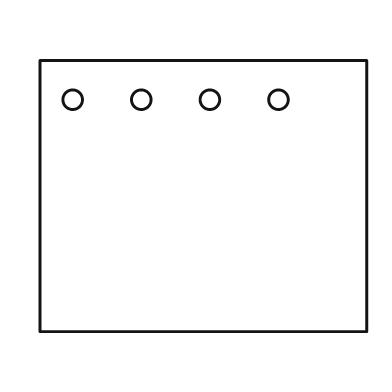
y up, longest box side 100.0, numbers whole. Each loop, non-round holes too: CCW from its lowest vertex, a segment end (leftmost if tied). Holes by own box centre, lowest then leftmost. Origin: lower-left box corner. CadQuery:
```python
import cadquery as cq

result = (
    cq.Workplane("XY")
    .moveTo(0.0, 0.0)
    .lineTo(100.0, 0.0)
    .lineTo(100.0, 83.0)
    .lineTo(0.0, 83.0)
    .close()
    .moveTo(10.0, 71.0)
    .circle(3.0)
    .moveTo(31.0, 71.0)
    .circle(3.0)
    .moveTo(52.0, 71.0)
    .circle(3.0)
    .moveTo(73.0, 71.0)
    .circle(3.0)
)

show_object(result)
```